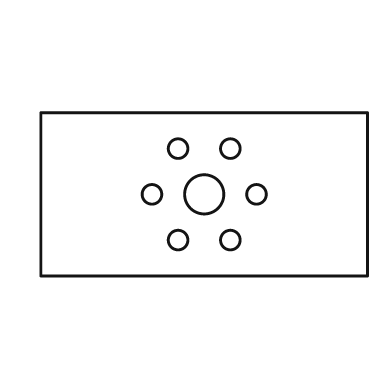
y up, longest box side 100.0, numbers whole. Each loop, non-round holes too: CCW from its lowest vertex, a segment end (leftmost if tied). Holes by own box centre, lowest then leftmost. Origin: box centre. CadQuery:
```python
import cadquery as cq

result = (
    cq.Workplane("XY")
    .moveTo(-50.0, -25.0)
    .lineTo(50.0, -25.0)
    .lineTo(50.0, 25.0)
    .lineTo(-50.0, 25.0)
    .close()
    .moveTo(-8.0, -14.0)
    .circle(3.0)
    .moveTo(8.0, -14.0)
    .circle(3.0)
    .moveTo(-16.0, 0.0)
    .circle(3.0)
    .moveTo(0.0, 0.0)
    .circle(6.0)
    .moveTo(16.0, 0.0)
    .circle(3.0)
    .moveTo(-8.0, 14.0)
    .circle(3.0)
    .moveTo(8.0, 14.0)
    .circle(3.0)
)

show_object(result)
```